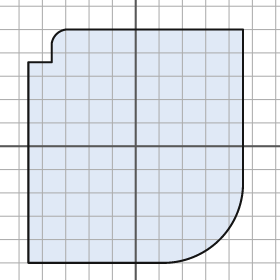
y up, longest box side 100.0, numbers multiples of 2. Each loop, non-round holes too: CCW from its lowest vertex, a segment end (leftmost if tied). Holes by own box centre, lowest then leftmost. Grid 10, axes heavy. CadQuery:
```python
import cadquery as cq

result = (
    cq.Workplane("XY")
    .moveTo(-46.0, -50.0)
    .lineTo(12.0, -50.0)
    .threePointArc((36.0, -40.0), (46.0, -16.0))
    .lineTo(46.0, 50.0)
    .lineTo(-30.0, 50.0)
    .threePointArc((-34.0, 48.0), (-36.0, 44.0))
    .lineTo(-36.0, 36.0)
    .lineTo(-46.0, 36.0)
    .close()
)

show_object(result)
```